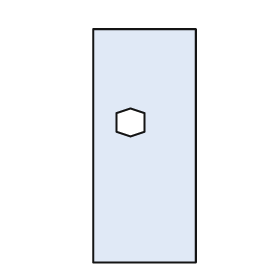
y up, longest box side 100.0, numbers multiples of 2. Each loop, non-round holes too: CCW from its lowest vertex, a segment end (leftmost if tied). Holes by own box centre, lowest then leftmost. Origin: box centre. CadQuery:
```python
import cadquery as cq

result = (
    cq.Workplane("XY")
    .moveTo(-22.0, -50.0)
    .lineTo(22.0, -50.0)
    .lineTo(22.0, 50.0)
    .lineTo(-22.0, 50.0)
    .close()
    .moveTo(-6.0, 4.0)
    .lineTo(0.0, 6.0)
    .lineTo(0.0, 14.0)
    .lineTo(-6.0, 16.0)
    .lineTo(-12.0, 14.0)
    .lineTo(-12.0, 6.0)
    .close()
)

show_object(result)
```